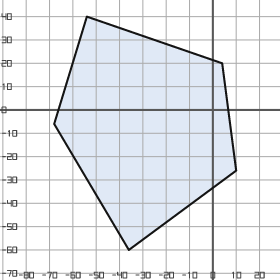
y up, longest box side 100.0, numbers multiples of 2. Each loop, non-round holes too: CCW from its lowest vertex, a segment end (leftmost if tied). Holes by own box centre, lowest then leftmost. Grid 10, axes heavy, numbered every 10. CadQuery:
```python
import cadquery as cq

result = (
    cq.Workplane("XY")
    .moveTo(-36.0, -60.0)
    .lineTo(10.0, -26.0)
    .lineTo(4.0, 20.0)
    .lineTo(-54.0, 40.0)
    .lineTo(-68.0, -6.0)
    .close()
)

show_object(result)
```